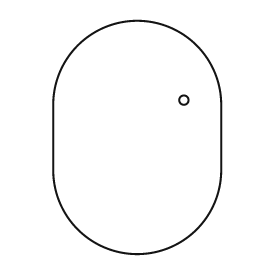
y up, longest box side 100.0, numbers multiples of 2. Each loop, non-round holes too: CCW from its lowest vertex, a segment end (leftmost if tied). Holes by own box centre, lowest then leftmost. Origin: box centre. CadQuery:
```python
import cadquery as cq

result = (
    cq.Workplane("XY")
    .moveTo(-36.0, -14.0)
    .threePointArc((0.0, -50.0), (36.0, -14.0))
    .lineTo(36.0, 14.0)
    .threePointArc((0.0, 50.0), (-36.0, 14.0))
    .close()
    .moveTo(20.0, 16.0)
    .circle(2.0)
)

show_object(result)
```